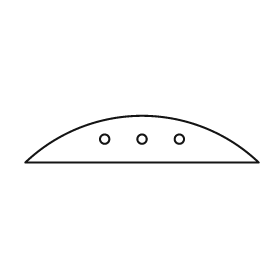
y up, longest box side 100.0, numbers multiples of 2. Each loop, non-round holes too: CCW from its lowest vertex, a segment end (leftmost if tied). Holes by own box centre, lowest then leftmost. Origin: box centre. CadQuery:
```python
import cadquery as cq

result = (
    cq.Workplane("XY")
    .moveTo(-50.0, -10.0)
    .lineTo(50.0, -10.0)
    .threePointArc((0.0, 10.0), (-50.0, -10.0))
    .close()
    .moveTo(-16.0, 0.0)
    .circle(2.0)
    .moveTo(0.0, 0.0)
    .circle(2.0)
    .moveTo(16.0, 0.0)
    .circle(2.0)
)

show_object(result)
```